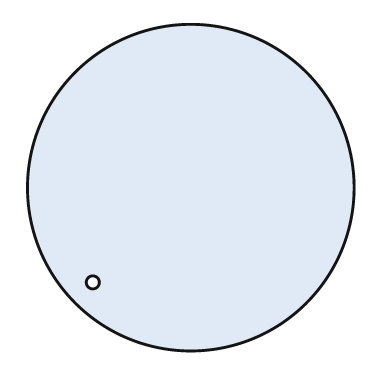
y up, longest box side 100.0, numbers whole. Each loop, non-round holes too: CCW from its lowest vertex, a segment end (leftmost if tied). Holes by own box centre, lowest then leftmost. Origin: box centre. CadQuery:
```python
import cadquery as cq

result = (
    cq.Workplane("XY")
    .moveTo(0.0, 0.0)
    .circle(50.0)
    .moveTo(-30.0, -29.0)
    .circle(2.0)
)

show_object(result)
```